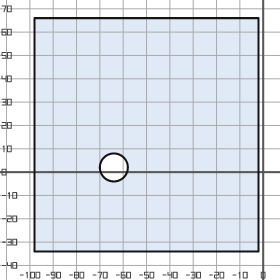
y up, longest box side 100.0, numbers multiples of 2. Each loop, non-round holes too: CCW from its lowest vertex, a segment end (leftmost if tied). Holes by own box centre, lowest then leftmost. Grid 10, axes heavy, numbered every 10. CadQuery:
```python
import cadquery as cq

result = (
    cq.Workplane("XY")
    .moveTo(-98.0, -34.0)
    .lineTo(-2.0, -34.0)
    .lineTo(-2.0, 66.0)
    .lineTo(-98.0, 66.0)
    .close()
    .moveTo(-64.0, 2.0)
    .circle(6.0)
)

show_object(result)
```